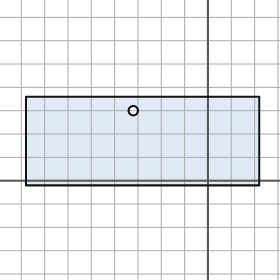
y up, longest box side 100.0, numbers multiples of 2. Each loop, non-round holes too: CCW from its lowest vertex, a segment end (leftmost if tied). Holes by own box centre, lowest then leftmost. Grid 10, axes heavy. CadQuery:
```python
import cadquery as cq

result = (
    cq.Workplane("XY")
    .moveTo(-78.0, -2.0)
    .lineTo(22.0, -2.0)
    .lineTo(22.0, 36.0)
    .lineTo(-78.0, 36.0)
    .close()
    .moveTo(-32.0, 30.0)
    .circle(2.0)
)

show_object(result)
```